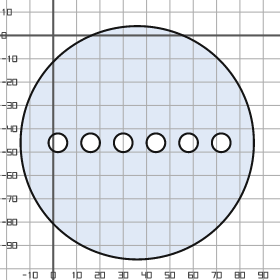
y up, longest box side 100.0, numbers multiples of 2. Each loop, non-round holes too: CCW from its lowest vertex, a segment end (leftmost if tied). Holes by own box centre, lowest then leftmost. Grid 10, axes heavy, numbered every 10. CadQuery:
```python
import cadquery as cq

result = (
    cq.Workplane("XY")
    .moveTo(36.0, -46.0)
    .circle(50.0)
    .moveTo(2.0, -46.0)
    .circle(4.0)
    .moveTo(16.0, -46.0)
    .circle(4.0)
    .moveTo(30.0, -46.0)
    .circle(4.0)
    .moveTo(44.0, -46.0)
    .circle(4.0)
    .moveTo(58.0, -46.0)
    .circle(4.0)
    .moveTo(72.0, -46.0)
    .circle(4.0)
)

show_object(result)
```